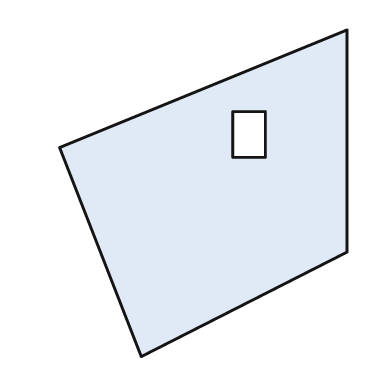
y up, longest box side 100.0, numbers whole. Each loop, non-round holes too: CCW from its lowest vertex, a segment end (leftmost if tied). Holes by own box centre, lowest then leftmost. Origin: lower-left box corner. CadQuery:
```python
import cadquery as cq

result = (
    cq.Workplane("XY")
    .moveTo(25.0, 0.0)
    .lineTo(88.0, 32.0)
    .lineTo(88.0, 100.0)
    .lineTo(0.0, 64.0)
    .close()
    .moveTo(53.0, 61.0)
    .lineTo(63.0, 61.0)
    .lineTo(63.0, 75.0)
    .lineTo(53.0, 75.0)
    .close()
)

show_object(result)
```